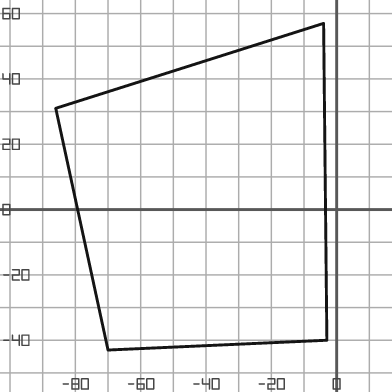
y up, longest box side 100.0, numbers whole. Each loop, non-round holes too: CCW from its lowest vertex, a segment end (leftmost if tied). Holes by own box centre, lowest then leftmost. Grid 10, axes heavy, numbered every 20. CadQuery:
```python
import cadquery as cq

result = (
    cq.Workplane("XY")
    .moveTo(-70.0, -43.0)
    .lineTo(-3.0, -40.0)
    .lineTo(-4.0, 57.0)
    .lineTo(-86.0, 31.0)
    .close()
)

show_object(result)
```